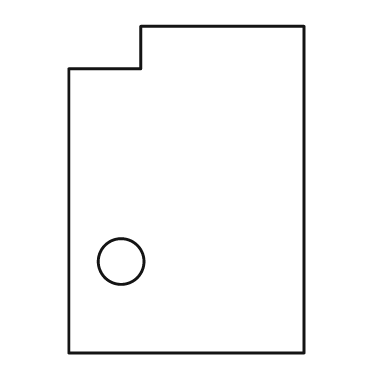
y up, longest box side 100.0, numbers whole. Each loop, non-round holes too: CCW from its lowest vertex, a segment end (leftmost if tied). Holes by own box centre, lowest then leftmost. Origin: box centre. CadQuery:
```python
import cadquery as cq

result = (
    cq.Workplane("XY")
    .moveTo(-36.0, -50.0)
    .lineTo(36.0, -50.0)
    .lineTo(36.0, 50.0)
    .lineTo(-14.0, 50.0)
    .lineTo(-14.0, 37.0)
    .lineTo(-36.0, 37.0)
    .close()
    .moveTo(-20.0, -22.0)
    .circle(7.0)
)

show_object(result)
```